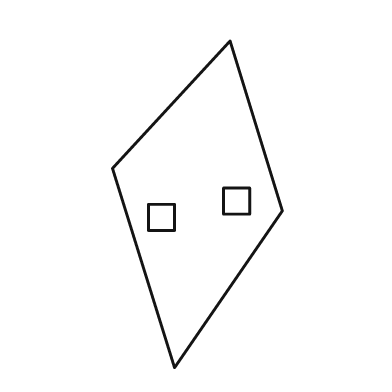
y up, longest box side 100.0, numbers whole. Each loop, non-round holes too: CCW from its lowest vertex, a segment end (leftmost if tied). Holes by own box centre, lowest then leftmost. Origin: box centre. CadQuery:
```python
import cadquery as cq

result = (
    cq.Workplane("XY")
    .moveTo(-7.0, -50.0)
    .lineTo(26.0, -2.0)
    .lineTo(10.0, 50.0)
    .lineTo(-26.0, 11.0)
    .close()
    .moveTo(-15.0, -8.0)
    .lineTo(-7.0, -8.0)
    .lineTo(-7.0, 0.0)
    .lineTo(-15.0, 0.0)
    .close()
    .moveTo(8.0, -3.0)
    .lineTo(16.0, -3.0)
    .lineTo(16.0, 5.0)
    .lineTo(8.0, 5.0)
    .close()
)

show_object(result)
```